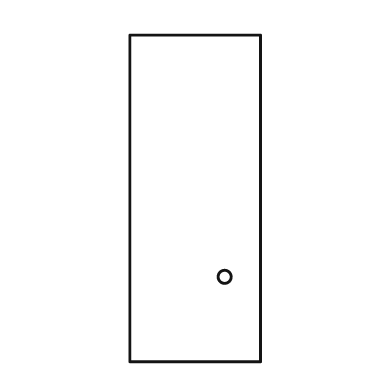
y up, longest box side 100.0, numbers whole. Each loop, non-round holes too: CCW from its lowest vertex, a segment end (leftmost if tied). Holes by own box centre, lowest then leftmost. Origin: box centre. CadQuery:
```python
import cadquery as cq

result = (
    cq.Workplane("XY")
    .moveTo(-20.0, -50.0)
    .lineTo(20.0, -50.0)
    .lineTo(20.0, 50.0)
    .lineTo(-20.0, 50.0)
    .close()
    .moveTo(9.0, -24.0)
    .circle(2.0)
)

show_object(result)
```